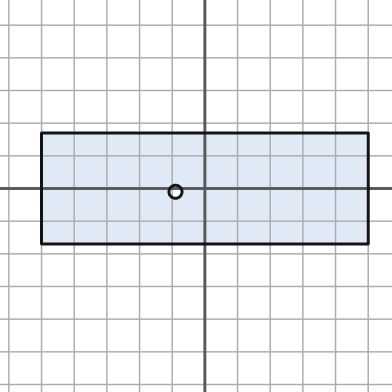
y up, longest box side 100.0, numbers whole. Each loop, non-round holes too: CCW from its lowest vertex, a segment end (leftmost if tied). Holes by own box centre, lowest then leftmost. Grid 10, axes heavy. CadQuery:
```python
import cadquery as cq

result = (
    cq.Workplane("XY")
    .moveTo(-50.0, -17.0)
    .lineTo(50.0, -17.0)
    .lineTo(50.0, 17.0)
    .lineTo(-50.0, 17.0)
    .close()
    .moveTo(-9.0, -1.0)
    .circle(2.0)
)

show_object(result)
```